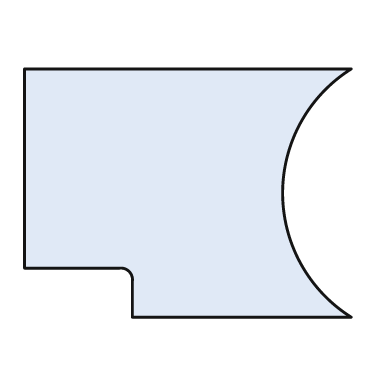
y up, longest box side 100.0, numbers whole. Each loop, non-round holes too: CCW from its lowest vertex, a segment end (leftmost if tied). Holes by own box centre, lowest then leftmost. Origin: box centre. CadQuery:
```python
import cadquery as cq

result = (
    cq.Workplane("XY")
    .moveTo(-17.0, -38.0)
    .lineTo(50.0, -38.0)
    .threePointArc((29.0, 0.0), (50.0, 38.0))
    .lineTo(-50.0, 38.0)
    .lineTo(-50.0, -23.0)
    .lineTo(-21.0, -23.0)
    .threePointArc((-18.0, -24.0), (-17.0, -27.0))
    .close()
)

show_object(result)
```